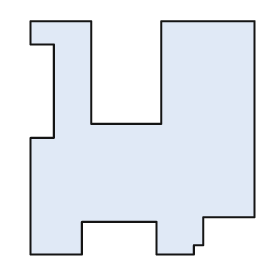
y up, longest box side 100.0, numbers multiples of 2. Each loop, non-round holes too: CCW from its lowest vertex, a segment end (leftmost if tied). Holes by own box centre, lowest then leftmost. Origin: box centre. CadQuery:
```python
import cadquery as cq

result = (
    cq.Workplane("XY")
    .moveTo(-48.0, -50.0)
    .lineTo(-26.0, -50.0)
    .lineTo(-26.0, -36.0)
    .lineTo(6.0, -36.0)
    .lineTo(6.0, -50.0)
    .lineTo(22.0, -50.0)
    .lineTo(22.0, -46.0)
    .lineTo(26.0, -46.0)
    .lineTo(26.0, -34.0)
    .lineTo(48.0, -34.0)
    .lineTo(48.0, 50.0)
    .lineTo(8.0, 50.0)
    .lineTo(8.0, 6.0)
    .lineTo(-22.0, 6.0)
    .lineTo(-22.0, 50.0)
    .lineTo(-48.0, 50.0)
    .lineTo(-48.0, 40.0)
    .lineTo(-38.0, 40.0)
    .lineTo(-38.0, 0.0)
    .lineTo(-48.0, 0.0)
    .close()
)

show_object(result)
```